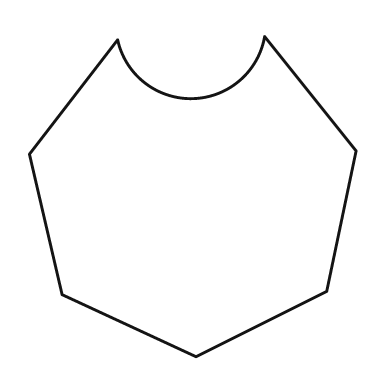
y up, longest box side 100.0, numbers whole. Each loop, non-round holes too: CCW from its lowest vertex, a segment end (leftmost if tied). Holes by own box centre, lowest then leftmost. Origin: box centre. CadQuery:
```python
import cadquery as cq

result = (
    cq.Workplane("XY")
    .moveTo(1.0, -49.0)
    .lineTo(41.0, -29.0)
    .lineTo(50.0, 14.0)
    .lineTo(22.0, 49.0)
    .threePointArc((0.0, 30.0), (-23.0, 48.0))
    .lineTo(-50.0, 13.0)
    .lineTo(-40.0, -30.0)
    .close()
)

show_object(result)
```